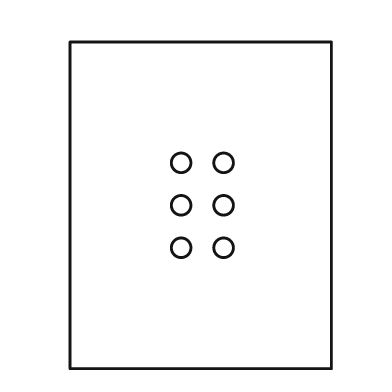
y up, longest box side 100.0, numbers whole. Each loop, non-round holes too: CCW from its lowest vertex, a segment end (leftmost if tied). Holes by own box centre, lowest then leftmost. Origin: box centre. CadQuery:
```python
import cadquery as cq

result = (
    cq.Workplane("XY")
    .moveTo(-40.0, -50.0)
    .lineTo(40.0, -50.0)
    .lineTo(40.0, 50.0)
    .lineTo(-40.0, 50.0)
    .close()
    .moveTo(-6.0, -13.0)
    .circle(3.0)
    .moveTo(7.0, -13.0)
    .circle(3.0)
    .moveTo(-6.0, 0.0)
    .circle(3.0)
    .moveTo(7.0, 0.0)
    .circle(3.0)
    .moveTo(-6.0, 13.0)
    .circle(3.0)
    .moveTo(7.0, 13.0)
    .circle(3.0)
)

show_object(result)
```